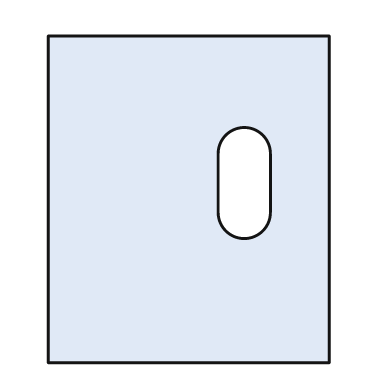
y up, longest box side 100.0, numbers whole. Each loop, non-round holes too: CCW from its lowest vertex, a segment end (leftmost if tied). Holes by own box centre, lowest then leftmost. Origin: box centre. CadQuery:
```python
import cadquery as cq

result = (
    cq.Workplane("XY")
    .moveTo(-43.0, -50.0)
    .lineTo(43.0, -50.0)
    .lineTo(43.0, 50.0)
    .lineTo(-43.0, 50.0)
    .close()
    .moveTo(9.0, -4.0)
    .threePointArc((17.0, -12.0), (25.0, -4.0))
    .lineTo(25.0, 14.0)
    .threePointArc((17.0, 22.0), (9.0, 14.0))
    .close()
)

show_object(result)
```